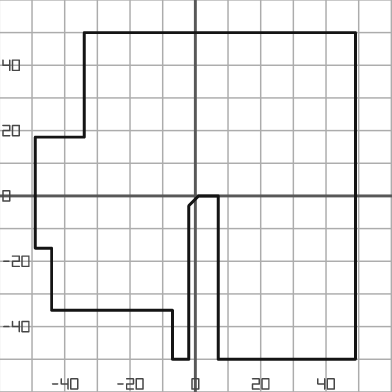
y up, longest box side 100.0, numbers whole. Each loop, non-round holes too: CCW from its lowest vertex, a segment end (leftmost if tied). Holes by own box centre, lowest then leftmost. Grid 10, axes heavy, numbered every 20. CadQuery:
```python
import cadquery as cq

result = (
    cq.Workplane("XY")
    .moveTo(-7.0, -50.0)
    .lineTo(-2.0, -50.0)
    .lineTo(-2.0, -3.0)
    .lineTo(1.0, 0.0)
    .lineTo(7.0, 0.0)
    .lineTo(7.0, -50.0)
    .lineTo(49.0, -50.0)
    .lineTo(49.0, 50.0)
    .lineTo(-34.0, 50.0)
    .lineTo(-34.0, 18.0)
    .lineTo(-49.0, 18.0)
    .lineTo(-49.0, -16.0)
    .lineTo(-44.0, -16.0)
    .lineTo(-44.0, -35.0)
    .lineTo(-7.0, -35.0)
    .close()
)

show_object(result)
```